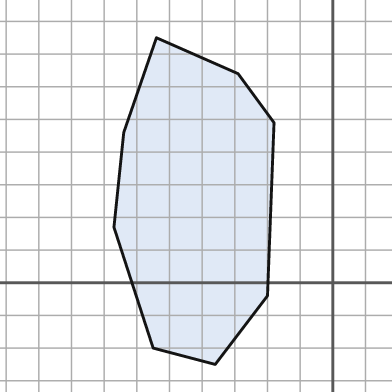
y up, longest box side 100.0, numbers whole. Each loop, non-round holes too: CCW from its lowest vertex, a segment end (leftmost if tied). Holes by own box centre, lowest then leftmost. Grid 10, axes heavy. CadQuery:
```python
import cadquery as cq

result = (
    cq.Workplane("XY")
    .moveTo(-36.0, -25.0)
    .lineTo(-20.0, -4.0)
    .lineTo(-18.0, 49.0)
    .lineTo(-29.0, 64.0)
    .lineTo(-54.0, 75.0)
    .lineTo(-64.0, 46.0)
    .lineTo(-67.0, 17.0)
    .lineTo(-55.0, -20.0)
    .close()
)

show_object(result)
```